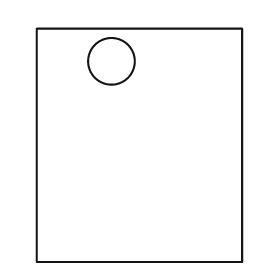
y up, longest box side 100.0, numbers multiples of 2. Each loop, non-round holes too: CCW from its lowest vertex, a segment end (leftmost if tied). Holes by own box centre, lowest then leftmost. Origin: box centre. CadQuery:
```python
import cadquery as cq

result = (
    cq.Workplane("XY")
    .moveTo(-44.0, -50.0)
    .lineTo(44.0, -50.0)
    .lineTo(44.0, 50.0)
    .lineTo(-44.0, 50.0)
    .close()
    .moveTo(-12.0, 36.0)
    .circle(10.0)
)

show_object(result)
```